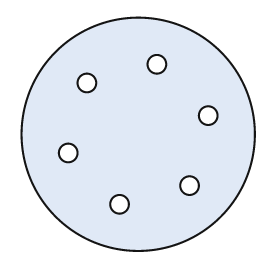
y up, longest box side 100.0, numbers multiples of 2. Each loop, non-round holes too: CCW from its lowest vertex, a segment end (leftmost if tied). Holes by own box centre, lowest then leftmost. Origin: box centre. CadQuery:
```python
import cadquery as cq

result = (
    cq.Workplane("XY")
    .moveTo(0.0, 0.0)
    .circle(50.0)
    .moveTo(-8.0, -30.0)
    .circle(4.0)
    .moveTo(22.0, -22.0)
    .circle(4.0)
    .moveTo(-30.0, -8.0)
    .circle(4.0)
    .moveTo(30.0, 8.0)
    .circle(4.0)
    .moveTo(-22.0, 22.0)
    .circle(4.0)
    .moveTo(8.0, 30.0)
    .circle(4.0)
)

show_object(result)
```